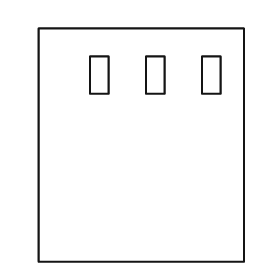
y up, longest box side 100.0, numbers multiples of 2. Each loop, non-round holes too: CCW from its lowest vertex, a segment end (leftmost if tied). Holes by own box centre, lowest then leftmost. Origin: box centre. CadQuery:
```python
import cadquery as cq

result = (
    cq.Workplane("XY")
    .moveTo(-44.0, -50.0)
    .lineTo(44.0, -50.0)
    .lineTo(44.0, 50.0)
    .lineTo(-44.0, 50.0)
    .close()
    .moveTo(-22.0, 22.0)
    .lineTo(-14.0, 22.0)
    .lineTo(-14.0, 38.0)
    .lineTo(-22.0, 38.0)
    .close()
    .moveTo(2.0, 22.0)
    .lineTo(10.0, 22.0)
    .lineTo(10.0, 38.0)
    .lineTo(2.0, 38.0)
    .close()
    .moveTo(26.0, 22.0)
    .lineTo(34.0, 22.0)
    .lineTo(34.0, 38.0)
    .lineTo(26.0, 38.0)
    .close()
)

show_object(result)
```